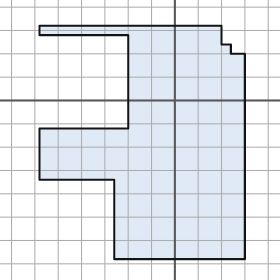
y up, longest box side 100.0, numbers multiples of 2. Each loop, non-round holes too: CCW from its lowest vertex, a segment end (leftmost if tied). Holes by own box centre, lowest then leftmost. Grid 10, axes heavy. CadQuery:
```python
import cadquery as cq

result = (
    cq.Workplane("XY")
    .moveTo(-26.0, -68.0)
    .lineTo(30.0, -68.0)
    .lineTo(30.0, 20.0)
    .lineTo(24.0, 20.0)
    .lineTo(24.0, 24.0)
    .lineTo(20.0, 24.0)
    .lineTo(20.0, 32.0)
    .lineTo(-58.0, 32.0)
    .lineTo(-58.0, 28.0)
    .lineTo(-20.0, 28.0)
    .lineTo(-20.0, -12.0)
    .lineTo(-58.0, -12.0)
    .lineTo(-58.0, -34.0)
    .lineTo(-26.0, -34.0)
    .close()
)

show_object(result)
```